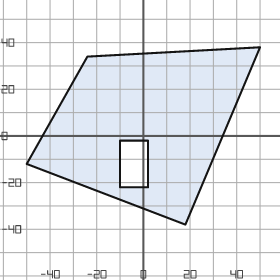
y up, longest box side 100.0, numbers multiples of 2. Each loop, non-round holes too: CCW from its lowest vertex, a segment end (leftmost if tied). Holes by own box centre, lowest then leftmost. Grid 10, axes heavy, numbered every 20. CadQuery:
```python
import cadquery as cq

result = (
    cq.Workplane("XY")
    .moveTo(18.0, -38.0)
    .lineTo(50.0, 38.0)
    .lineTo(-24.0, 34.0)
    .lineTo(-50.0, -12.0)
    .close()
    .moveTo(-10.0, -22.0)
    .lineTo(2.0, -22.0)
    .lineTo(2.0, -2.0)
    .lineTo(-10.0, -2.0)
    .close()
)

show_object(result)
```